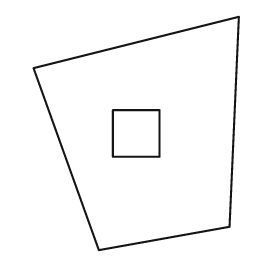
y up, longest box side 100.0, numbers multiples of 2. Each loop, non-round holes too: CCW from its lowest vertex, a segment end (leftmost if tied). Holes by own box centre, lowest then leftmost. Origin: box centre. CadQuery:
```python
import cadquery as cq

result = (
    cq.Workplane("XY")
    .moveTo(-16.0, -50.0)
    .lineTo(40.0, -40.0)
    .lineTo(44.0, 50.0)
    .lineTo(-44.0, 28.0)
    .close()
    .moveTo(-10.0, -10.0)
    .lineTo(10.0, -10.0)
    .lineTo(10.0, 10.0)
    .lineTo(-10.0, 10.0)
    .close()
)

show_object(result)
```